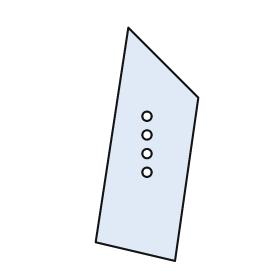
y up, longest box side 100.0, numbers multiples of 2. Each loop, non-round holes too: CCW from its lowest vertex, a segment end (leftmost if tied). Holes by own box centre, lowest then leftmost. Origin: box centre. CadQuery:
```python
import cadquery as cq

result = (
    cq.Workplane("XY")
    .moveTo(12.0, -50.0)
    .lineTo(22.0, 20.0)
    .lineTo(-8.0, 50.0)
    .lineTo(-22.0, -42.0)
    .close()
    .moveTo(0.0, -12.0)
    .circle(2.0)
    .moveTo(0.0, -4.0)
    .circle(2.0)
    .moveTo(0.0, 4.0)
    .circle(2.0)
    .moveTo(0.0, 12.0)
    .circle(2.0)
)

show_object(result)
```